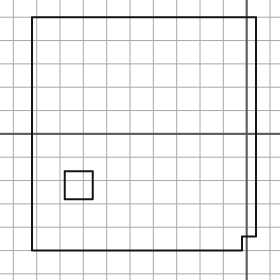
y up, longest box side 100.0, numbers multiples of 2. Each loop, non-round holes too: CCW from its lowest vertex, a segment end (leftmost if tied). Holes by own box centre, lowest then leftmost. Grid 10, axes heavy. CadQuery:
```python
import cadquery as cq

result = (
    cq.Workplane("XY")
    .moveTo(-92.0, -50.0)
    .lineTo(-2.0, -50.0)
    .lineTo(-2.0, -44.0)
    .lineTo(4.0, -44.0)
    .lineTo(4.0, 50.0)
    .lineTo(-92.0, 50.0)
    .close()
    .moveTo(-78.0, -28.0)
    .lineTo(-66.0, -28.0)
    .lineTo(-66.0, -16.0)
    .lineTo(-78.0, -16.0)
    .close()
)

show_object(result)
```